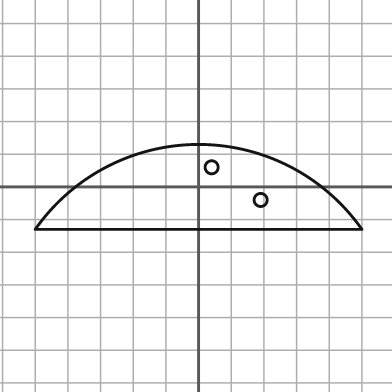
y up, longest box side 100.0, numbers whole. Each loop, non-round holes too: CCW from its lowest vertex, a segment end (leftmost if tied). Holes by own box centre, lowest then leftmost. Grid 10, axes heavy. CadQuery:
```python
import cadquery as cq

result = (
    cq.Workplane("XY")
    .moveTo(-50.0, -13.0)
    .lineTo(50.0, -13.0)
    .threePointArc((0.0, 13.0), (-50.0, -13.0))
    .close()
    .moveTo(19.0, -4.0)
    .circle(2.0)
    .moveTo(4.0, 6.0)
    .circle(2.0)
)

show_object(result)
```